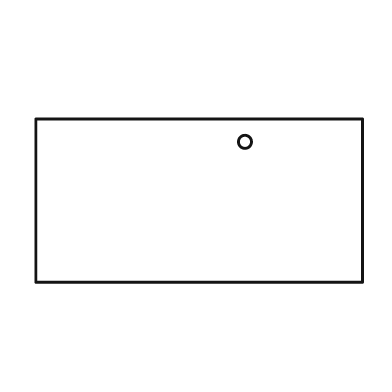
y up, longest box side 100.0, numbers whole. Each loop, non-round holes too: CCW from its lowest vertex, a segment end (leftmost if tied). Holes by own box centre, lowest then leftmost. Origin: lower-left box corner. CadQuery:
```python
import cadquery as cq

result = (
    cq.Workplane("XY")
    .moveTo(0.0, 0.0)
    .lineTo(100.0, 0.0)
    .lineTo(100.0, 50.0)
    .lineTo(0.0, 50.0)
    .close()
    .moveTo(64.0, 43.0)
    .circle(2.0)
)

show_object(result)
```